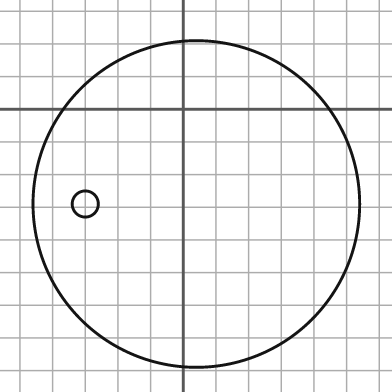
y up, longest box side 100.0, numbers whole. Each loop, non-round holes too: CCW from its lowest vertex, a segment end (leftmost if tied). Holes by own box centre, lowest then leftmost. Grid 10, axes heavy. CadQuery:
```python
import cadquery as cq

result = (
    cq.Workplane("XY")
    .moveTo(4.0, -29.0)
    .circle(50.0)
    .moveTo(-30.0, -29.0)
    .circle(4.0)
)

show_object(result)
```